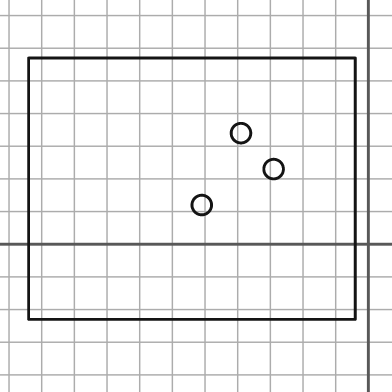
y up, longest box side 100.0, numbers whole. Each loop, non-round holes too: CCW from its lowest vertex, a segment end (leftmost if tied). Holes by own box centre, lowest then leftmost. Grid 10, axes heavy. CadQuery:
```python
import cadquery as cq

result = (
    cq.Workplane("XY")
    .moveTo(-104.0, -23.0)
    .lineTo(-4.0, -23.0)
    .lineTo(-4.0, 57.0)
    .lineTo(-104.0, 57.0)
    .close()
    .moveTo(-51.0, 12.0)
    .circle(3.0)
    .moveTo(-29.0, 23.0)
    .circle(3.0)
    .moveTo(-39.0, 34.0)
    .circle(3.0)
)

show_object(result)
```